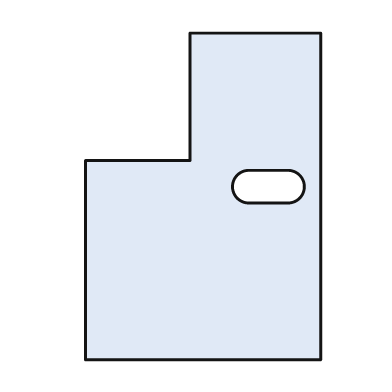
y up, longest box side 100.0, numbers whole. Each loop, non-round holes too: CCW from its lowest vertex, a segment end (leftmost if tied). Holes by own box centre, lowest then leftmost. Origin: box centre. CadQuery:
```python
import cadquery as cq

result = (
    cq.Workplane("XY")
    .moveTo(-36.0, -50.0)
    .lineTo(36.0, -50.0)
    .lineTo(36.0, 50.0)
    .lineTo(-4.0, 50.0)
    .lineTo(-4.0, 11.0)
    .lineTo(-36.0, 11.0)
    .close()
    .moveTo(14.0, -2.0)
    .lineTo(26.0, -2.0)
    .threePointArc((31.0, 3.0), (26.0, 8.0))
    .lineTo(14.0, 8.0)
    .threePointArc((9.0, 3.0), (14.0, -2.0))
    .close()
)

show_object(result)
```